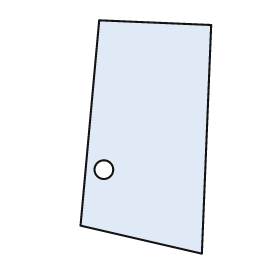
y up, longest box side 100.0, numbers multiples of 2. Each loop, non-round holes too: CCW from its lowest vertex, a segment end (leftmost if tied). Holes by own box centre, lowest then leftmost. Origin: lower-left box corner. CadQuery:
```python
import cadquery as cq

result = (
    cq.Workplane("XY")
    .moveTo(52.0, 0.0)
    .lineTo(56.0, 98.0)
    .lineTo(8.0, 100.0)
    .lineTo(0.0, 12.0)
    .close()
    .moveTo(10.0, 36.0)
    .circle(4.0)
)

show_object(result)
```